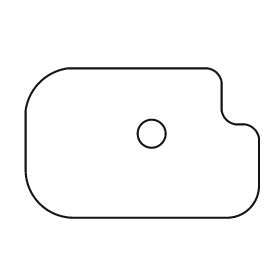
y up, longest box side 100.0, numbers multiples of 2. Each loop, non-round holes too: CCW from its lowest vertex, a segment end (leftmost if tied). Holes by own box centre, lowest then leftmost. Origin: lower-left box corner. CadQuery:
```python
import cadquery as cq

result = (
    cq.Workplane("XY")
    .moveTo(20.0, 0.0)
    .lineTo(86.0, 0.0)
    .threePointArc((96.0, 4.0), (100.0, 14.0))
    .lineTo(100.0, 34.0)
    .threePointArc((98.0, 38.0), (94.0, 40.0))
    .lineTo(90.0, 40.0)
    .threePointArc((86.0, 42.0), (84.0, 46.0))
    .lineTo(84.0, 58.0)
    .threePointArc((82.0, 62.0), (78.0, 64.0))
    .lineTo(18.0, 64.0)
    .threePointArc((6.0, 58.0), (0.0, 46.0))
    .lineTo(0.0, 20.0)
    .threePointArc((6.0, 6.0), (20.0, 0.0))
    .close()
    .moveTo(54.0, 36.0)
    .circle(6.0)
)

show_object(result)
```